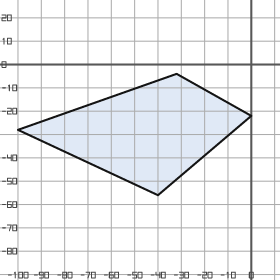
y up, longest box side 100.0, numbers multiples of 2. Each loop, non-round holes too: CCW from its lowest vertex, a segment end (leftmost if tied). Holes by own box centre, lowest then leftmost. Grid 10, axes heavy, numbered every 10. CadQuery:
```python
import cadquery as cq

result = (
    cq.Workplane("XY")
    .moveTo(-40.0, -56.0)
    .lineTo(0.0, -22.0)
    .lineTo(-32.0, -4.0)
    .lineTo(-100.0, -28.0)
    .close()
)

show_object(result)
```